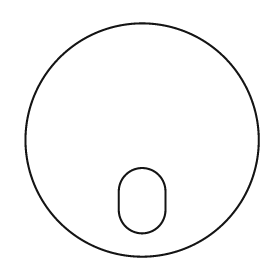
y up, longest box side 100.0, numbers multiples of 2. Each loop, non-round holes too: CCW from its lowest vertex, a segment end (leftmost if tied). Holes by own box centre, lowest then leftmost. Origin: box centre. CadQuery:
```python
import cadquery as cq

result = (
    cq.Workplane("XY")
    .moveTo(0.0, 0.0)
    .circle(50.0)
    .moveTo(-10.0, -30.0)
    .threePointArc((0.0, -40.0), (10.0, -30.0))
    .lineTo(10.0, -22.0)
    .threePointArc((0.0, -12.0), (-10.0, -22.0))
    .close()
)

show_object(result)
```